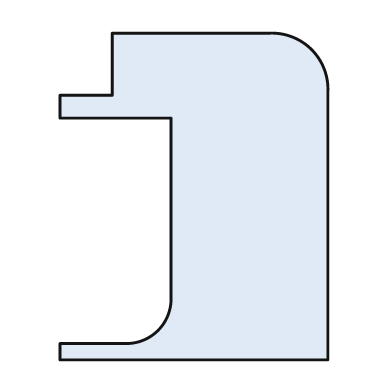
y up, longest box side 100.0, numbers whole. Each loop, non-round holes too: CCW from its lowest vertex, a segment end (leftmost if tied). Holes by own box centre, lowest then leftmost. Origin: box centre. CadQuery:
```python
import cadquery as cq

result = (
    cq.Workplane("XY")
    .moveTo(-41.0, -50.0)
    .lineTo(41.0, -50.0)
    .lineTo(41.0, 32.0)
    .threePointArc((36.0, 45.0), (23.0, 50.0))
    .lineTo(-25.0, 50.0)
    .lineTo(-25.0, 31.0)
    .lineTo(-41.0, 31.0)
    .lineTo(-41.0, 24.0)
    .lineTo(-7.0, 24.0)
    .lineTo(-7.0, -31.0)
    .threePointArc((-11.0, -41.0), (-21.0, -45.0))
    .lineTo(-41.0, -45.0)
    .close()
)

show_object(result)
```